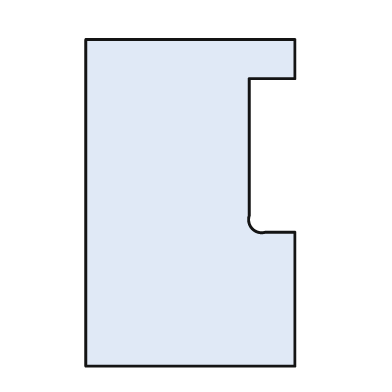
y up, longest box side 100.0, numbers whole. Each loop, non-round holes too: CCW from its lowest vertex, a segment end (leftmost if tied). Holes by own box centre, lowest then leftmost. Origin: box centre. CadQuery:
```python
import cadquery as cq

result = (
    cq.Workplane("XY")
    .moveTo(-32.0, -50.0)
    .lineTo(32.0, -50.0)
    .lineTo(32.0, -9.0)
    .lineTo(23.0, -9.0)
    .threePointArc((19.0, -8.0), (18.0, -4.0))
    .lineTo(18.0, 38.0)
    .lineTo(32.0, 38.0)
    .lineTo(32.0, 50.0)
    .lineTo(-32.0, 50.0)
    .close()
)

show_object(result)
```